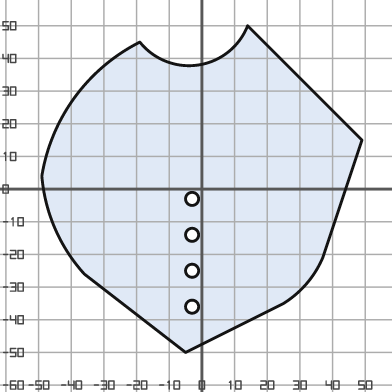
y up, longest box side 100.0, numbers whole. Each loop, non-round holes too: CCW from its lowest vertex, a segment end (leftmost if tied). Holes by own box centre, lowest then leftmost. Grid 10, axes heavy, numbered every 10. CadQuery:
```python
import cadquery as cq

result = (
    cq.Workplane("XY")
    .moveTo(-5.0, -50.0)
    .lineTo(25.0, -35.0)
    .threePointArc((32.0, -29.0), (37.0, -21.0))
    .lineTo(49.0, 15.0)
    .lineTo(14.0, 50.0)
    .threePointArc((-1.0, 38.0), (-19.0, 45.0))
    .threePointArc((-39.0, 28.0), (-49.0, 4.0))
    .threePointArc((-45.0, -12.0), (-36.0, -26.0))
    .close()
    .moveTo(-3.0, -36.0)
    .circle(2.0)
    .moveTo(-3.0, -25.0)
    .circle(2.0)
    .moveTo(-3.0, -14.0)
    .circle(2.0)
    .moveTo(-3.0, -3.0)
    .circle(2.0)
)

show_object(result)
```